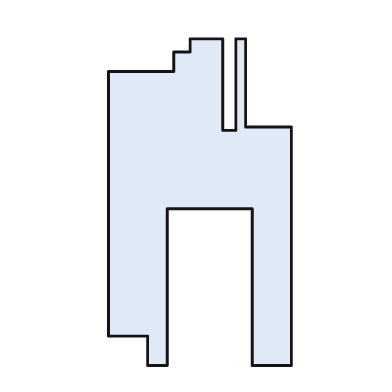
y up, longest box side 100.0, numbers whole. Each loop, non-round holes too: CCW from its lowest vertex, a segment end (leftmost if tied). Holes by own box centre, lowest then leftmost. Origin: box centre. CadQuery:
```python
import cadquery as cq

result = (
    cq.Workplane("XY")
    .moveTo(-16.0, -50.0)
    .lineTo(-10.0, -50.0)
    .lineTo(-10.0, -2.0)
    .lineTo(16.0, -2.0)
    .lineTo(16.0, -50.0)
    .lineTo(28.0, -50.0)
    .lineTo(28.0, 23.0)
    .lineTo(14.0, 23.0)
    .lineTo(14.0, 50.0)
    .lineTo(11.0, 50.0)
    .lineTo(11.0, 22.0)
    .lineTo(7.0, 22.0)
    .lineTo(7.0, 50.0)
    .lineTo(-3.0, 50.0)
    .lineTo(-3.0, 46.0)
    .lineTo(-8.0, 46.0)
    .lineTo(-8.0, 40.0)
    .lineTo(-28.0, 40.0)
    .lineTo(-28.0, -41.0)
    .lineTo(-16.0, -41.0)
    .close()
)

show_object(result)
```